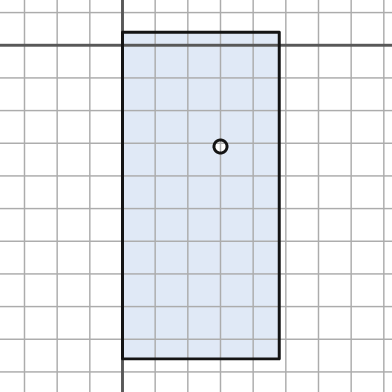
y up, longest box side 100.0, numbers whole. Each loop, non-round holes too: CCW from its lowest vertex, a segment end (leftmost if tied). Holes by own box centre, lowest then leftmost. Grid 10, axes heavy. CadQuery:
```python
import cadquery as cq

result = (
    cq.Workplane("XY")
    .moveTo(0.0, -96.0)
    .lineTo(48.0, -96.0)
    .lineTo(48.0, 4.0)
    .lineTo(0.0, 4.0)
    .close()
    .moveTo(30.0, -31.0)
    .circle(2.0)
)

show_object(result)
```